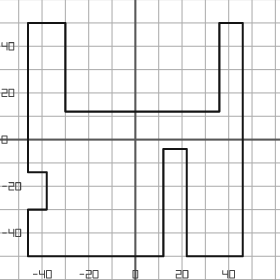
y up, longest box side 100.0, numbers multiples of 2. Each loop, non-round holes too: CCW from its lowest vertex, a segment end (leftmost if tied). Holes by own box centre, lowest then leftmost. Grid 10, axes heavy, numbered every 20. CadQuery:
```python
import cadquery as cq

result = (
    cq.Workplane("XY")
    .moveTo(-46.0, -50.0)
    .lineTo(12.0, -50.0)
    .lineTo(12.0, -4.0)
    .lineTo(22.0, -4.0)
    .lineTo(22.0, -50.0)
    .lineTo(46.0, -50.0)
    .lineTo(46.0, 50.0)
    .lineTo(36.0, 50.0)
    .lineTo(36.0, 12.0)
    .lineTo(-30.0, 12.0)
    .lineTo(-30.0, 50.0)
    .lineTo(-46.0, 50.0)
    .lineTo(-46.0, -14.0)
    .lineTo(-38.0, -14.0)
    .lineTo(-38.0, -30.0)
    .lineTo(-46.0, -30.0)
    .close()
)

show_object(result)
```